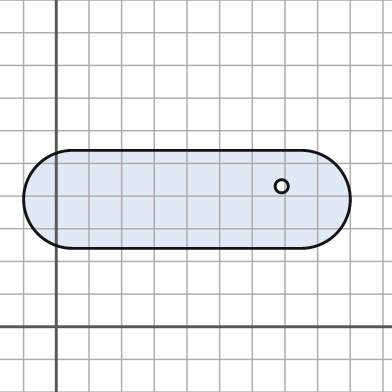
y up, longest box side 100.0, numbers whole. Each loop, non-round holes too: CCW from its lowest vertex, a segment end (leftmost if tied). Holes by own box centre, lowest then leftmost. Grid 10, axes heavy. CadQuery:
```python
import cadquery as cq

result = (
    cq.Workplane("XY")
    .moveTo(5.0, 24.0)
    .lineTo(75.0, 24.0)
    .threePointArc((90.0, 39.0), (75.0, 54.0))
    .lineTo(5.0, 54.0)
    .threePointArc((-10.0, 39.0), (5.0, 24.0))
    .close()
    .moveTo(69.0, 43.0)
    .circle(2.0)
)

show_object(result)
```